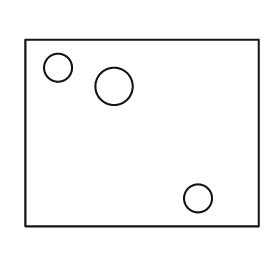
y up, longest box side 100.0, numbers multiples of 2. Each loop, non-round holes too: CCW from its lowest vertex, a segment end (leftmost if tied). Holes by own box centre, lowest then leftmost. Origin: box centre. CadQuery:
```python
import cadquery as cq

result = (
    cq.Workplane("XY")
    .moveTo(-50.0, -40.0)
    .lineTo(50.0, -40.0)
    .lineTo(50.0, 40.0)
    .lineTo(-50.0, 40.0)
    .close()
    .moveTo(24.0, -28.0)
    .circle(6.0)
    .moveTo(-12.0, 20.0)
    .circle(8.0)
    .moveTo(-36.0, 28.0)
    .circle(6.0)
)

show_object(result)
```